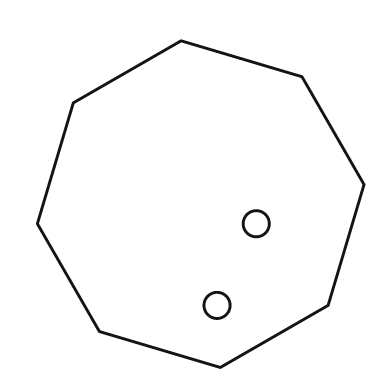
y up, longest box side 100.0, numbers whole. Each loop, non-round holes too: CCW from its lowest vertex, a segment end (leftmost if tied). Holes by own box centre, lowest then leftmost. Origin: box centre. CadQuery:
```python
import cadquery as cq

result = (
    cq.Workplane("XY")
    .moveTo(6.0, -50.0)
    .lineTo(39.0, -31.0)
    .lineTo(50.0, 6.0)
    .lineTo(31.0, 39.0)
    .lineTo(-6.0, 50.0)
    .lineTo(-39.0, 31.0)
    .lineTo(-50.0, -6.0)
    .lineTo(-31.0, -39.0)
    .close()
    .moveTo(5.0, -31.0)
    .circle(4.0)
    .moveTo(17.0, -6.0)
    .circle(4.0)
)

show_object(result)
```